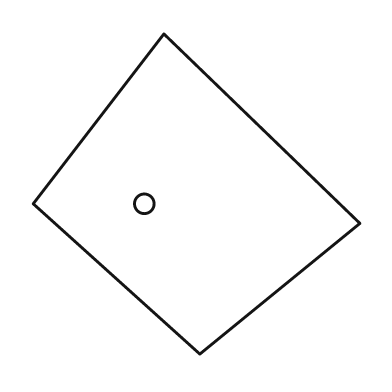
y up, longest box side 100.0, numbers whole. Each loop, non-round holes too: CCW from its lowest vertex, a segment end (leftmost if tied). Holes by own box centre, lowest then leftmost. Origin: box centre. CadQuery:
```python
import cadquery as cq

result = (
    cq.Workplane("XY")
    .moveTo(1.0, -49.0)
    .lineTo(50.0, -9.0)
    .lineTo(-10.0, 49.0)
    .lineTo(-50.0, -3.0)
    .close()
    .moveTo(-16.0, -3.0)
    .circle(3.0)
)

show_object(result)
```